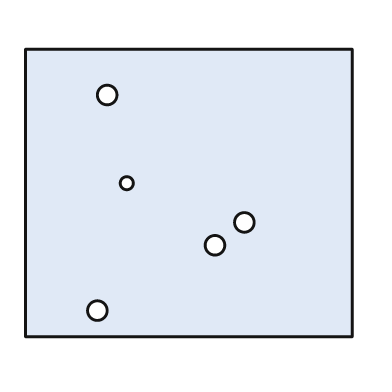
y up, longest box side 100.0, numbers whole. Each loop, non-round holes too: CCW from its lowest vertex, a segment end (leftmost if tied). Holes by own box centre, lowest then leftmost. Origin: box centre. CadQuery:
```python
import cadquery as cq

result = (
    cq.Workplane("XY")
    .moveTo(-50.0, -44.0)
    .lineTo(50.0, -44.0)
    .lineTo(50.0, 44.0)
    .lineTo(-50.0, 44.0)
    .close()
    .moveTo(-28.0, -36.0)
    .circle(3.0)
    .moveTo(8.0, -16.0)
    .circle(3.0)
    .moveTo(17.0, -9.0)
    .circle(3.0)
    .moveTo(-19.0, 3.0)
    .circle(2.0)
    .moveTo(-25.0, 30.0)
    .circle(3.0)
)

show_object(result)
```